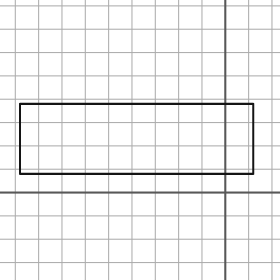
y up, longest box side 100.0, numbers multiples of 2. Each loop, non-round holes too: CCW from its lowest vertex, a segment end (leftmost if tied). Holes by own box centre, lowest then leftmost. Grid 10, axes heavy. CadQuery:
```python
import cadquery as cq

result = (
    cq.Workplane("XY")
    .moveTo(-88.0, 8.0)
    .lineTo(12.0, 8.0)
    .lineTo(12.0, 38.0)
    .lineTo(-88.0, 38.0)
    .close()
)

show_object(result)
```